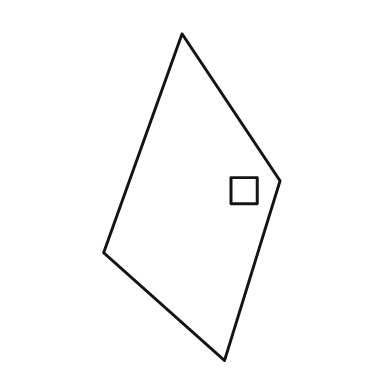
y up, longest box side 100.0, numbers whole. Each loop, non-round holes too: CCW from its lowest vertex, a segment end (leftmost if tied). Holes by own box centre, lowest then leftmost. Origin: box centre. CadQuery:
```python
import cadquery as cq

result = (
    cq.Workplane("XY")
    .moveTo(10.0, -50.0)
    .lineTo(27.0, 5.0)
    .lineTo(-3.0, 50.0)
    .lineTo(-27.0, -17.0)
    .close()
    .moveTo(12.0, -2.0)
    .lineTo(20.0, -2.0)
    .lineTo(20.0, 6.0)
    .lineTo(12.0, 6.0)
    .close()
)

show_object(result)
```